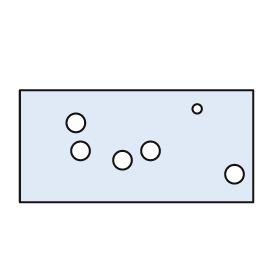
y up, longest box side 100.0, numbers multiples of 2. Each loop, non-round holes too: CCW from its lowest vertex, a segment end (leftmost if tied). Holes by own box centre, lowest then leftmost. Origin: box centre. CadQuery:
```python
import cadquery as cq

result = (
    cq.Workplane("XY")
    .moveTo(-50.0, -24.0)
    .lineTo(50.0, -24.0)
    .lineTo(50.0, 24.0)
    .lineTo(-50.0, 24.0)
    .close()
    .moveTo(42.0, -12.0)
    .circle(4.0)
    .moveTo(-6.0, -6.0)
    .circle(4.0)
    .moveTo(-24.0, -2.0)
    .circle(4.0)
    .moveTo(6.0, -2.0)
    .circle(4.0)
    .moveTo(-26.0, 10.0)
    .circle(4.0)
    .moveTo(26.0, 16.0)
    .circle(2.0)
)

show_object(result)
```